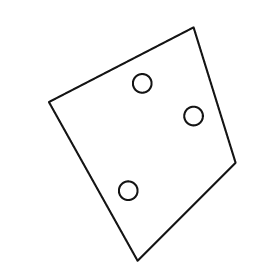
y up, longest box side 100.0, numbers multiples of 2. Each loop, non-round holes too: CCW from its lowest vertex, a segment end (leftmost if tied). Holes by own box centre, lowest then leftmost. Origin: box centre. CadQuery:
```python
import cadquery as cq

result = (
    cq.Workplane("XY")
    .moveTo(-2.0, -50.0)
    .lineTo(40.0, -8.0)
    .lineTo(22.0, 50.0)
    .lineTo(-40.0, 18.0)
    .close()
    .moveTo(-6.0, -20.0)
    .circle(4.0)
    .moveTo(22.0, 12.0)
    .circle(4.0)
    .moveTo(0.0, 26.0)
    .circle(4.0)
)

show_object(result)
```